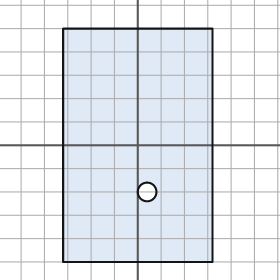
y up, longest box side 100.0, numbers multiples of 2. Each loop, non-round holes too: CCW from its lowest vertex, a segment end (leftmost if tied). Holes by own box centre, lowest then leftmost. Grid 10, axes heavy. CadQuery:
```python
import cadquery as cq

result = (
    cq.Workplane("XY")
    .moveTo(-32.0, -50.0)
    .lineTo(32.0, -50.0)
    .lineTo(32.0, 50.0)
    .lineTo(-32.0, 50.0)
    .close()
    .moveTo(4.0, -20.0)
    .circle(4.0)
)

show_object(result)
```